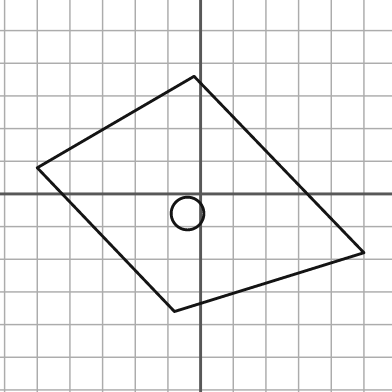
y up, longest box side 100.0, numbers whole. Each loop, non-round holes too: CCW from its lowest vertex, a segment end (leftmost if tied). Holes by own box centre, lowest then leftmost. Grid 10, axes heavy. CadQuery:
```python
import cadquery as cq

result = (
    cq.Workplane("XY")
    .moveTo(-8.0, -36.0)
    .lineTo(50.0, -18.0)
    .lineTo(-2.0, 36.0)
    .lineTo(-50.0, 8.0)
    .close()
    .moveTo(-4.0, -6.0)
    .circle(5.0)
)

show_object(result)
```